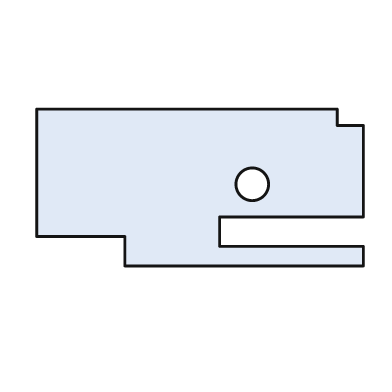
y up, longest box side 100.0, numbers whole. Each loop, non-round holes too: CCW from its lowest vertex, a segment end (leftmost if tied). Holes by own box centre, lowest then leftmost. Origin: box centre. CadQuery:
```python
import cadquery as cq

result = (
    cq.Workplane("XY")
    .moveTo(-23.0, -24.0)
    .lineTo(50.0, -24.0)
    .lineTo(50.0, -18.0)
    .lineTo(6.0, -18.0)
    .lineTo(6.0, -9.0)
    .lineTo(50.0, -9.0)
    .lineTo(50.0, 19.0)
    .lineTo(42.0, 19.0)
    .lineTo(42.0, 24.0)
    .lineTo(-50.0, 24.0)
    .lineTo(-50.0, -15.0)
    .lineTo(-23.0, -15.0)
    .close()
    .moveTo(16.0, 1.0)
    .circle(5.0)
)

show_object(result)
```